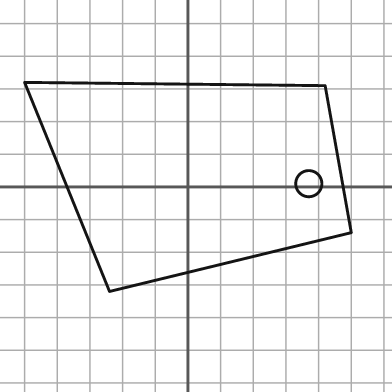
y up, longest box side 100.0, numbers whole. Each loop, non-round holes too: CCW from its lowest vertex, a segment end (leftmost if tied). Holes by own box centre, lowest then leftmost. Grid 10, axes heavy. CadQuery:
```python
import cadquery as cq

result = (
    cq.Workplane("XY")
    .moveTo(-24.0, -32.0)
    .lineTo(50.0, -14.0)
    .lineTo(42.0, 31.0)
    .lineTo(-50.0, 32.0)
    .close()
    .moveTo(37.0, 1.0)
    .circle(4.0)
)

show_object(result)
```